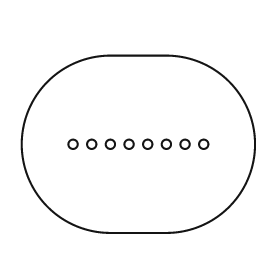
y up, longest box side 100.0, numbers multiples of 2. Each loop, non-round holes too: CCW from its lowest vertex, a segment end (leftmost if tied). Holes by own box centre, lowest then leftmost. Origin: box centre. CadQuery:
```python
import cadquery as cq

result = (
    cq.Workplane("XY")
    .moveTo(-12.0, -38.0)
    .lineTo(12.0, -38.0)
    .threePointArc((50.0, 0.0), (12.0, 38.0))
    .lineTo(-12.0, 38.0)
    .threePointArc((-50.0, 0.0), (-12.0, -38.0))
    .close()
    .moveTo(-28.0, 0.0)
    .circle(2.0)
    .moveTo(-20.0, 0.0)
    .circle(2.0)
    .moveTo(-12.0, 0.0)
    .circle(2.0)
    .moveTo(-4.0, 0.0)
    .circle(2.0)
    .moveTo(4.0, 0.0)
    .circle(2.0)
    .moveTo(12.0, 0.0)
    .circle(2.0)
    .moveTo(20.0, 0.0)
    .circle(2.0)
    .moveTo(28.0, 0.0)
    .circle(2.0)
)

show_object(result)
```